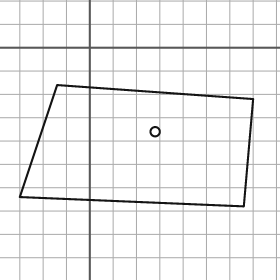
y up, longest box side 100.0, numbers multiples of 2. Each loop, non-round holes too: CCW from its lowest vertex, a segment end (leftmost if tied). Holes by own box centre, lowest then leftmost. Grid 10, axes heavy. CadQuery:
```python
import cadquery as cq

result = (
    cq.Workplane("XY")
    .moveTo(66.0, -68.0)
    .lineTo(70.0, -22.0)
    .lineTo(-14.0, -16.0)
    .lineTo(-30.0, -64.0)
    .close()
    .moveTo(28.0, -36.0)
    .circle(2.0)
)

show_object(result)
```